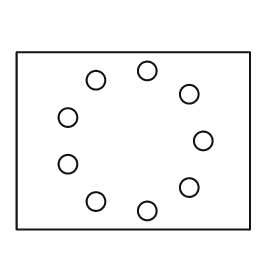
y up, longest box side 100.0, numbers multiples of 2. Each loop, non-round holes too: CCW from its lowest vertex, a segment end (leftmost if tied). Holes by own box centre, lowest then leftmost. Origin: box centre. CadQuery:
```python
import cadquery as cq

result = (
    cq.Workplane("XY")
    .moveTo(-50.0, -38.0)
    .lineTo(50.0, -38.0)
    .lineTo(50.0, 38.0)
    .lineTo(-50.0, 38.0)
    .close()
    .moveTo(6.0, -30.0)
    .circle(4.0)
    .moveTo(-16.0, -26.0)
    .circle(4.0)
    .moveTo(24.0, -20.0)
    .circle(4.0)
    .moveTo(-28.0, -10.0)
    .circle(4.0)
    .moveTo(30.0, 0.0)
    .circle(4.0)
    .moveTo(-28.0, 10.0)
    .circle(4.0)
    .moveTo(24.0, 20.0)
    .circle(4.0)
    .moveTo(-16.0, 26.0)
    .circle(4.0)
    .moveTo(6.0, 30.0)
    .circle(4.0)
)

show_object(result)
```